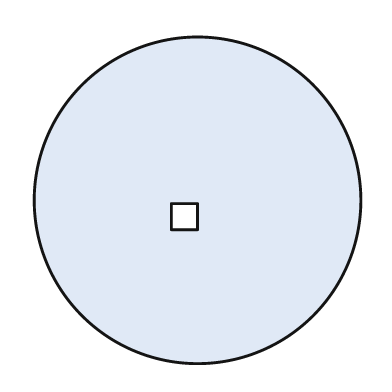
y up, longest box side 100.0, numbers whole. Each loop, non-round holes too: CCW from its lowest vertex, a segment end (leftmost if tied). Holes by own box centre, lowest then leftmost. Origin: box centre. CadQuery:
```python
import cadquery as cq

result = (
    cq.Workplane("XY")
    .moveTo(0.0, 0.0)
    .circle(50.0)
    .moveTo(-8.0, -9.0)
    .lineTo(0.0, -9.0)
    .lineTo(0.0, -1.0)
    .lineTo(-8.0, -1.0)
    .close()
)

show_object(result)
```